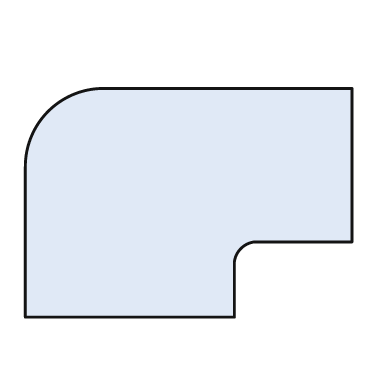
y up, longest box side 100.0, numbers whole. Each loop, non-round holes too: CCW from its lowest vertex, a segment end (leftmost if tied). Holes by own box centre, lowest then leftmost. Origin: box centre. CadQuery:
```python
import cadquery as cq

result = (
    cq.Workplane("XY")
    .moveTo(-50.0, -35.0)
    .lineTo(14.0, -35.0)
    .lineTo(14.0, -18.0)
    .threePointArc((16.0, -14.0), (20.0, -12.0))
    .lineTo(50.0, -12.0)
    .lineTo(50.0, 35.0)
    .lineTo(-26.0, 35.0)
    .threePointArc((-43.0, 28.0), (-50.0, 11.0))
    .close()
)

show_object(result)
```